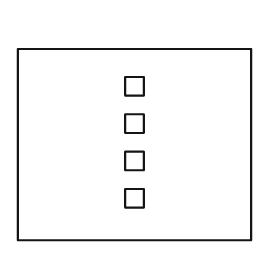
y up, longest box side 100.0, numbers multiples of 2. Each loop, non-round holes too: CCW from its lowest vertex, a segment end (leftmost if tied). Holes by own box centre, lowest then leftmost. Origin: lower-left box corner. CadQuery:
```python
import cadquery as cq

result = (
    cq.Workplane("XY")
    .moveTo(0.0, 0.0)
    .lineTo(100.0, 0.0)
    .lineTo(100.0, 82.0)
    .lineTo(0.0, 82.0)
    .close()
    .moveTo(46.0, 14.0)
    .lineTo(54.0, 14.0)
    .lineTo(54.0, 22.0)
    .lineTo(46.0, 22.0)
    .close()
    .moveTo(46.0, 30.0)
    .lineTo(54.0, 30.0)
    .lineTo(54.0, 38.0)
    .lineTo(46.0, 38.0)
    .close()
    .moveTo(46.0, 46.0)
    .lineTo(54.0, 46.0)
    .lineTo(54.0, 54.0)
    .lineTo(46.0, 54.0)
    .close()
    .moveTo(46.0, 62.0)
    .lineTo(54.0, 62.0)
    .lineTo(54.0, 70.0)
    .lineTo(46.0, 70.0)
    .close()
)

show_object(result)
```